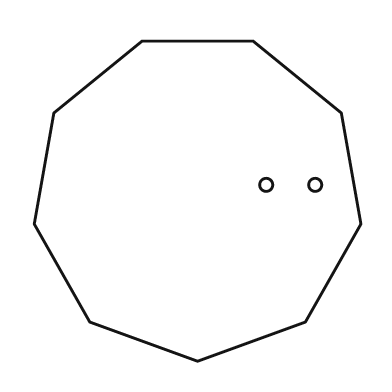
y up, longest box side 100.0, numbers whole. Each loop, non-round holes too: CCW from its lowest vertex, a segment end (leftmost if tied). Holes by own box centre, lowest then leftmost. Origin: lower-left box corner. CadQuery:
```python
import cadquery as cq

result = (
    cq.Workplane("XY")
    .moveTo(50.0, 0.0)
    .lineTo(83.0, 12.0)
    .lineTo(100.0, 42.0)
    .lineTo(94.0, 76.0)
    .lineTo(67.0, 98.0)
    .lineTo(33.0, 98.0)
    .lineTo(6.0, 76.0)
    .lineTo(0.0, 42.0)
    .lineTo(17.0, 12.0)
    .close()
    .moveTo(71.0, 54.0)
    .circle(2.0)
    .moveTo(86.0, 54.0)
    .circle(2.0)
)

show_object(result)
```